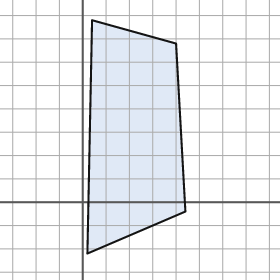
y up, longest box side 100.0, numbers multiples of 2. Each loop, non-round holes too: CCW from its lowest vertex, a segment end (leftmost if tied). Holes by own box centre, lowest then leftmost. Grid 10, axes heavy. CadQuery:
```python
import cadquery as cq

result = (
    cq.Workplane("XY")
    .moveTo(2.0, -22.0)
    .lineTo(44.0, -4.0)
    .lineTo(40.0, 68.0)
    .lineTo(4.0, 78.0)
    .close()
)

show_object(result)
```